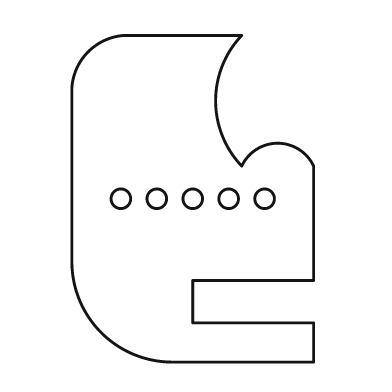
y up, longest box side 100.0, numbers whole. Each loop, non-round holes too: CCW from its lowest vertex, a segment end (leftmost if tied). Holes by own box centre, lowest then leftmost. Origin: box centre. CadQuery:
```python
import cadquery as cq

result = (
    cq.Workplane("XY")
    .moveTo(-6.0, -50.0)
    .lineTo(37.0, -50.0)
    .lineTo(37.0, -38.0)
    .lineTo(0.0, -38.0)
    .lineTo(0.0, -25.0)
    .lineTo(37.0, -25.0)
    .lineTo(37.0, 10.0)
    .threePointArc((26.0, 17.0), (15.0, 10.0))
    .threePointArc((7.0, 30.0), (15.0, 50.0))
    .lineTo(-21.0, 50.0)
    .threePointArc((-32.0, 45.0), (-37.0, 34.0))
    .lineTo(-37.0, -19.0)
    .threePointArc((-28.0, -41.0), (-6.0, -50.0))
    .close()
    .moveTo(-22.0, 0.0)
    .circle(3.0)
    .moveTo(-11.0, 0.0)
    .circle(3.0)
    .moveTo(0.0, 0.0)
    .circle(3.0)
    .moveTo(11.0, 0.0)
    .circle(3.0)
    .moveTo(22.0, 0.0)
    .circle(3.0)
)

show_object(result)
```